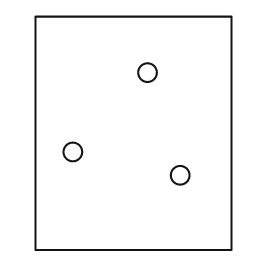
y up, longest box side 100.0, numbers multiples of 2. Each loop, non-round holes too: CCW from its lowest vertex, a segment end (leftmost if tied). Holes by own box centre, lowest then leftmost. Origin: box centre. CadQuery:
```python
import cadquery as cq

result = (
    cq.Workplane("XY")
    .moveTo(-42.0, -50.0)
    .lineTo(42.0, -50.0)
    .lineTo(42.0, 50.0)
    .lineTo(-42.0, 50.0)
    .close()
    .moveTo(20.0, -18.0)
    .circle(4.0)
    .moveTo(-26.0, -8.0)
    .circle(4.0)
    .moveTo(6.0, 26.0)
    .circle(4.0)
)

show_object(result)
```